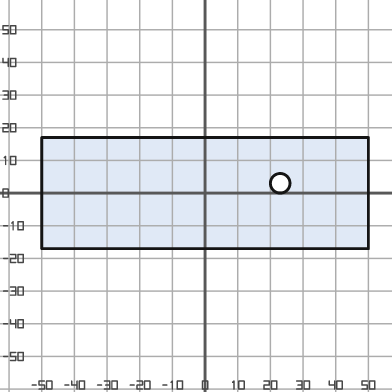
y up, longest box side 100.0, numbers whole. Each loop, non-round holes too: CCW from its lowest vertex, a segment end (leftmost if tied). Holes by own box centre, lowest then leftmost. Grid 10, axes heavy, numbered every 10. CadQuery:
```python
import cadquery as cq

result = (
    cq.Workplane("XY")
    .moveTo(-50.0, -17.0)
    .lineTo(50.0, -17.0)
    .lineTo(50.0, 17.0)
    .lineTo(-50.0, 17.0)
    .close()
    .moveTo(23.0, 3.0)
    .circle(3.0)
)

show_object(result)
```